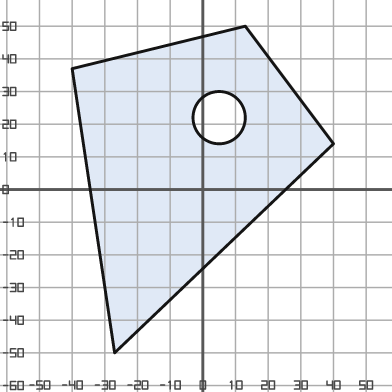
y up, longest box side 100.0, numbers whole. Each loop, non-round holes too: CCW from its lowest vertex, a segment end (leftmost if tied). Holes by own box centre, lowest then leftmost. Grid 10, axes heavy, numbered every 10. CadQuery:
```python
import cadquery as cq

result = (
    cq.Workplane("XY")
    .moveTo(-27.0, -50.0)
    .lineTo(40.0, 14.0)
    .lineTo(13.0, 50.0)
    .lineTo(-40.0, 37.0)
    .close()
    .moveTo(5.0, 22.0)
    .circle(8.0)
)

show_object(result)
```